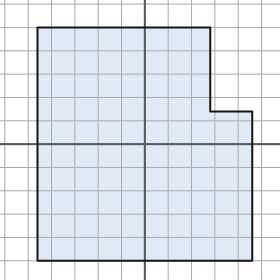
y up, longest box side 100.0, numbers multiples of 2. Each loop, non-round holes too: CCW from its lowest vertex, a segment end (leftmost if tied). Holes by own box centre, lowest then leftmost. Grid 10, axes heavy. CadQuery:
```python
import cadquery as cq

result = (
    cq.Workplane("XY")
    .moveTo(-46.0, -50.0)
    .lineTo(46.0, -50.0)
    .lineTo(46.0, 14.0)
    .lineTo(28.0, 14.0)
    .lineTo(28.0, 50.0)
    .lineTo(-46.0, 50.0)
    .close()
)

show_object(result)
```